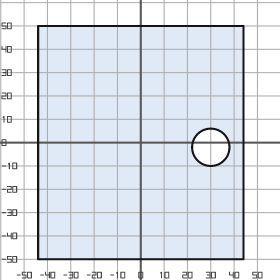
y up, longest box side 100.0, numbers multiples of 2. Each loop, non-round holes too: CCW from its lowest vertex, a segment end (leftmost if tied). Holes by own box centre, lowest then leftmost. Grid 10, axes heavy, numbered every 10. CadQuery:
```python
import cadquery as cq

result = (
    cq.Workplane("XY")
    .moveTo(-44.0, -50.0)
    .lineTo(44.0, -50.0)
    .lineTo(44.0, 50.0)
    .lineTo(-44.0, 50.0)
    .close()
    .moveTo(30.0, -2.0)
    .circle(8.0)
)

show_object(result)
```